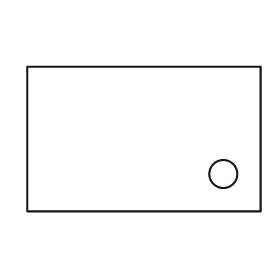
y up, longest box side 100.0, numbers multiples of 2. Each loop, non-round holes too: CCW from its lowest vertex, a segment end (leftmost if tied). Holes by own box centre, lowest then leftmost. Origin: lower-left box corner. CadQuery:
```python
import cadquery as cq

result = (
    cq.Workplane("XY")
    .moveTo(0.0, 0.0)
    .lineTo(100.0, 0.0)
    .lineTo(100.0, 62.0)
    .lineTo(0.0, 62.0)
    .close()
    .moveTo(84.0, 16.0)
    .circle(6.0)
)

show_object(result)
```